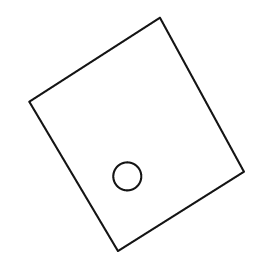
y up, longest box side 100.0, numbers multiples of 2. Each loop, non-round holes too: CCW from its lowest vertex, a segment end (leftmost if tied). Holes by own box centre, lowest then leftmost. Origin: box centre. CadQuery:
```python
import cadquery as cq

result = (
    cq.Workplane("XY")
    .moveTo(-8.0, -50.0)
    .lineTo(46.0, -16.0)
    .lineTo(10.0, 50.0)
    .lineTo(-46.0, 14.0)
    .close()
    .moveTo(-4.0, -18.0)
    .circle(6.0)
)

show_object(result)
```